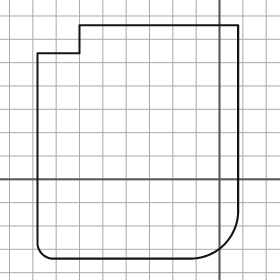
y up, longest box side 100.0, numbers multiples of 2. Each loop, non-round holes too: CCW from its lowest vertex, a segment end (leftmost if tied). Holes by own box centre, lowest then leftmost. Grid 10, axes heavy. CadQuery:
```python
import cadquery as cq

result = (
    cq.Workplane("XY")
    .moveTo(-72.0, -34.0)
    .lineTo(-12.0, -34.0)
    .threePointArc((2.0, -28.0), (8.0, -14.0))
    .lineTo(8.0, 66.0)
    .lineTo(-60.0, 66.0)
    .lineTo(-60.0, 54.0)
    .lineTo(-78.0, 54.0)
    .lineTo(-78.0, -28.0)
    .threePointArc((-76.0, -32.0), (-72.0, -34.0))
    .close()
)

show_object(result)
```